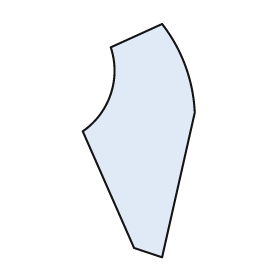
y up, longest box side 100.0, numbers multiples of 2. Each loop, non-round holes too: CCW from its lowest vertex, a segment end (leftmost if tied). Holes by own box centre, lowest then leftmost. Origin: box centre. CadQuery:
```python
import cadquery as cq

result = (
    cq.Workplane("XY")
    .moveTo(10.0, -50.0)
    .lineTo(24.0, 12.0)
    .threePointArc((20.0, 32.0), (10.0, 50.0))
    .lineTo(-12.0, 40.0)
    .threePointArc((-12.0, 20.0), (-24.0, 4.0))
    .lineTo(-2.0, -46.0)
    .close()
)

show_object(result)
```